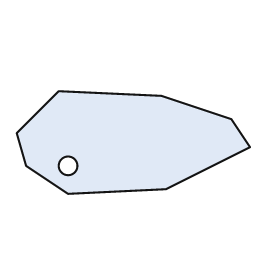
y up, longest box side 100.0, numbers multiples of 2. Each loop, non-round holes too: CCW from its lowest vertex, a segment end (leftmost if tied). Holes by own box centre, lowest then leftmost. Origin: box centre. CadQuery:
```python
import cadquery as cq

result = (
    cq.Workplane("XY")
    .moveTo(-28.0, -22.0)
    .lineTo(14.0, -20.0)
    .lineTo(50.0, -2.0)
    .lineTo(42.0, 10.0)
    .lineTo(12.0, 20.0)
    .lineTo(-32.0, 22.0)
    .lineTo(-50.0, 4.0)
    .lineTo(-46.0, -10.0)
    .close()
    .moveTo(-28.0, -10.0)
    .circle(4.0)
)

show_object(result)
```